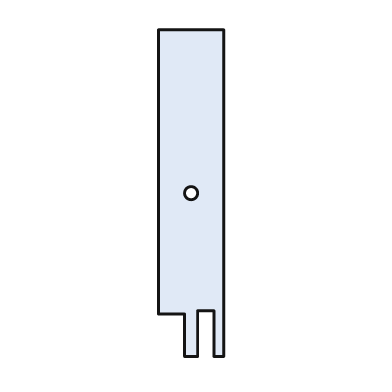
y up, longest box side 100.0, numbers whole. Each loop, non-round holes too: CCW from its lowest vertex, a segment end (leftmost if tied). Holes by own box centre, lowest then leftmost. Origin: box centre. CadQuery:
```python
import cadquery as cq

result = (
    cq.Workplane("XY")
    .moveTo(-2.0, -50.0)
    .lineTo(2.0, -50.0)
    .lineTo(2.0, -36.0)
    .lineTo(7.0, -36.0)
    .lineTo(7.0, -50.0)
    .lineTo(10.0, -50.0)
    .lineTo(10.0, 50.0)
    .lineTo(-10.0, 50.0)
    .lineTo(-10.0, -37.0)
    .lineTo(-2.0, -37.0)
    .close()
    .moveTo(0.0, 0.0)
    .circle(2.0)
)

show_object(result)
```